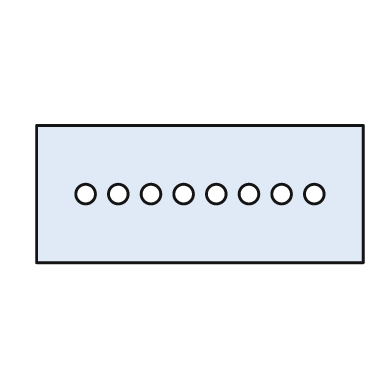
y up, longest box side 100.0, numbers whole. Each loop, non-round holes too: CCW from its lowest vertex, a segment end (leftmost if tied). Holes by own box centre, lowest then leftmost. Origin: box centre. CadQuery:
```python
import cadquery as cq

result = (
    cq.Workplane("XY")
    .moveTo(-50.0, -21.0)
    .lineTo(50.0, -21.0)
    .lineTo(50.0, 21.0)
    .lineTo(-50.0, 21.0)
    .close()
    .moveTo(-35.0, 0.0)
    .circle(3.0)
    .moveTo(-25.0, 0.0)
    .circle(3.0)
    .moveTo(-15.0, 0.0)
    .circle(3.0)
    .moveTo(-5.0, 0.0)
    .circle(3.0)
    .moveTo(5.0, 0.0)
    .circle(3.0)
    .moveTo(15.0, 0.0)
    .circle(3.0)
    .moveTo(25.0, 0.0)
    .circle(3.0)
    .moveTo(35.0, 0.0)
    .circle(3.0)
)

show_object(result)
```